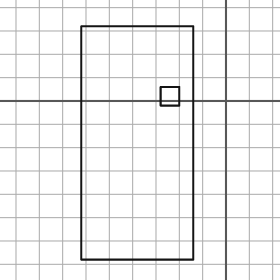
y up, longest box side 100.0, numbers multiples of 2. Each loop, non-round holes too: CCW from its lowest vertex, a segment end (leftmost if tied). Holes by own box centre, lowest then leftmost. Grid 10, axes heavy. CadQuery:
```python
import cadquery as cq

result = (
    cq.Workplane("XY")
    .moveTo(-62.0, -68.0)
    .lineTo(-14.0, -68.0)
    .lineTo(-14.0, 32.0)
    .lineTo(-62.0, 32.0)
    .close()
    .moveTo(-28.0, -2.0)
    .lineTo(-20.0, -2.0)
    .lineTo(-20.0, 6.0)
    .lineTo(-28.0, 6.0)
    .close()
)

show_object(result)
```